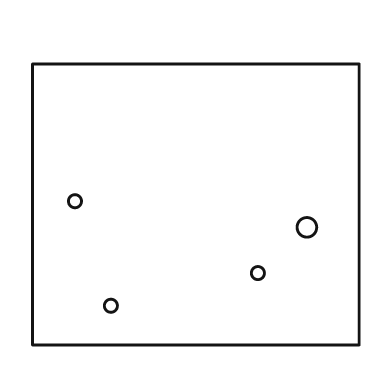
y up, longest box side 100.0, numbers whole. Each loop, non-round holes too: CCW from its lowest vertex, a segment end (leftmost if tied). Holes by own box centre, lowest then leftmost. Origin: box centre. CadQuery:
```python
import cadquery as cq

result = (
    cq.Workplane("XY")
    .moveTo(-50.0, -43.0)
    .lineTo(50.0, -43.0)
    .lineTo(50.0, 43.0)
    .lineTo(-50.0, 43.0)
    .close()
    .moveTo(-26.0, -31.0)
    .circle(2.0)
    .moveTo(19.0, -21.0)
    .circle(2.0)
    .moveTo(34.0, -7.0)
    .circle(3.0)
    .moveTo(-37.0, 1.0)
    .circle(2.0)
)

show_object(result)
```